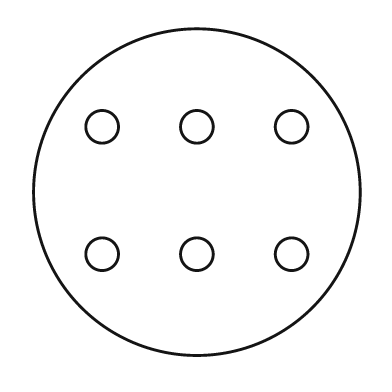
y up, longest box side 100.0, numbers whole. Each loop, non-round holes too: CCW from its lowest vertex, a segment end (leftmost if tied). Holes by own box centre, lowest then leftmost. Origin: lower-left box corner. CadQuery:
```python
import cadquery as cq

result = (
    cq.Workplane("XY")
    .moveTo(50.0, 50.0)
    .circle(50.0)
    .moveTo(21.0, 31.0)
    .circle(5.0)
    .moveTo(50.0, 31.0)
    .circle(5.0)
    .moveTo(79.0, 31.0)
    .circle(5.0)
    .moveTo(21.0, 70.0)
    .circle(5.0)
    .moveTo(50.0, 70.0)
    .circle(5.0)
    .moveTo(79.0, 70.0)
    .circle(5.0)
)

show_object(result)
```